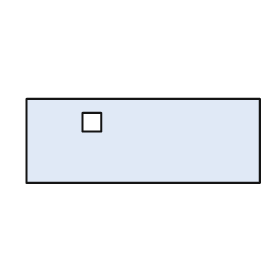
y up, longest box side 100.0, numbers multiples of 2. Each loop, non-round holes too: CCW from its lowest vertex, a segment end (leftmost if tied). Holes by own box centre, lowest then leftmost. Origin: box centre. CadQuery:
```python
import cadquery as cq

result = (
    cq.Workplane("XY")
    .moveTo(-50.0, -18.0)
    .lineTo(50.0, -18.0)
    .lineTo(50.0, 18.0)
    .lineTo(-50.0, 18.0)
    .close()
    .moveTo(-26.0, 4.0)
    .lineTo(-18.0, 4.0)
    .lineTo(-18.0, 12.0)
    .lineTo(-26.0, 12.0)
    .close()
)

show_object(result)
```